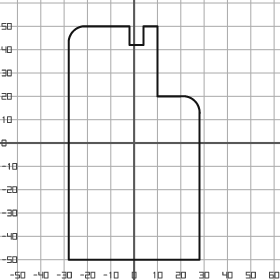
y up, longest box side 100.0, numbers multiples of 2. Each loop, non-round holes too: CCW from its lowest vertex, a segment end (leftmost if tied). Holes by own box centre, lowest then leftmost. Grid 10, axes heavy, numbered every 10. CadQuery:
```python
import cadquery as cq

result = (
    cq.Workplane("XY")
    .moveTo(-28.0, -50.0)
    .lineTo(28.0, -50.0)
    .lineTo(28.0, 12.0)
    .threePointArc((26.0, 18.0), (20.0, 20.0))
    .lineTo(10.0, 20.0)
    .lineTo(10.0, 50.0)
    .lineTo(4.0, 50.0)
    .lineTo(4.0, 42.0)
    .lineTo(-2.0, 42.0)
    .lineTo(-2.0, 50.0)
    .lineTo(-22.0, 50.0)
    .threePointArc((-26.0, 48.0), (-28.0, 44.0))
    .close()
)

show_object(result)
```